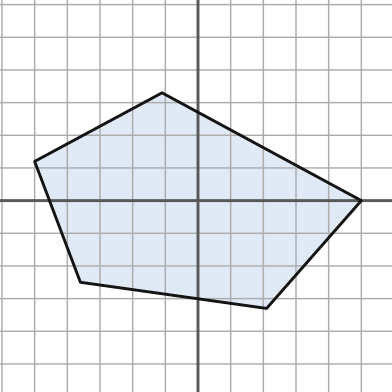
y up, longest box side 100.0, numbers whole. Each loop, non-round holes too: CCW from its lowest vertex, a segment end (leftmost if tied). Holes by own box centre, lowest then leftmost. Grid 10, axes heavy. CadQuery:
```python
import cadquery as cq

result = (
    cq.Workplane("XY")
    .moveTo(21.0, -33.0)
    .lineTo(50.0, 0.0)
    .lineTo(-11.0, 33.0)
    .lineTo(-50.0, 12.0)
    .lineTo(-36.0, -25.0)
    .close()
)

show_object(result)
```